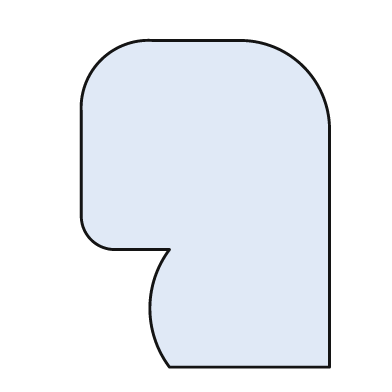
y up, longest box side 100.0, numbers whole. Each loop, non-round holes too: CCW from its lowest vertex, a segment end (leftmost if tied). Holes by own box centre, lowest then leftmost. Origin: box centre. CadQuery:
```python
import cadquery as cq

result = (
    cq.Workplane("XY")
    .moveTo(-11.0, -50.0)
    .lineTo(38.0, -50.0)
    .lineTo(38.0, 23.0)
    .threePointArc((30.0, 42.0), (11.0, 50.0))
    .lineTo(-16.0, 50.0)
    .threePointArc((-32.0, 44.0), (-38.0, 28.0))
    .lineTo(-38.0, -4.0)
    .threePointArc((-35.0, -11.0), (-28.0, -14.0))
    .lineTo(-11.0, -14.0)
    .threePointArc((-17.0, -32.0), (-11.0, -50.0))
    .close()
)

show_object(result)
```